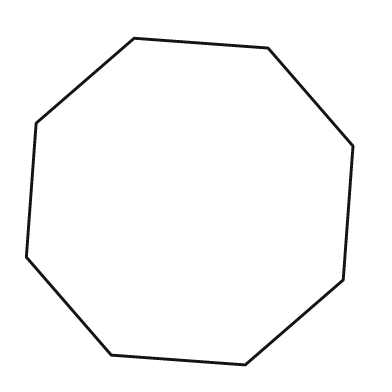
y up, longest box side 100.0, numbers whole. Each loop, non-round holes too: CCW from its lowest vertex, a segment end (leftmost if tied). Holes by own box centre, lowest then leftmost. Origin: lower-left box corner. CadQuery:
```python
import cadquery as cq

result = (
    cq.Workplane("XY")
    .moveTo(67.0, 0.0)
    .lineTo(97.0, 26.0)
    .lineTo(100.0, 67.0)
    .lineTo(74.0, 97.0)
    .lineTo(33.0, 100.0)
    .lineTo(3.0, 74.0)
    .lineTo(0.0, 33.0)
    .lineTo(26.0, 3.0)
    .close()
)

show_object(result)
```